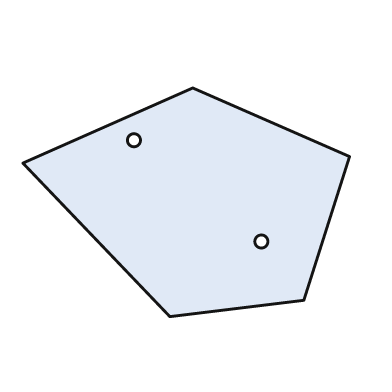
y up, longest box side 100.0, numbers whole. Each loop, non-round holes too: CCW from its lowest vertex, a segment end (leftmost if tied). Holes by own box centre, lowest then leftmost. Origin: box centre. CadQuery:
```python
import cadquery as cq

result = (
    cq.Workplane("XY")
    .moveTo(-5.0, -35.0)
    .lineTo(36.0, -30.0)
    .lineTo(50.0, 14.0)
    .lineTo(2.0, 35.0)
    .lineTo(-50.0, 12.0)
    .close()
    .moveTo(23.0, -12.0)
    .circle(2.0)
    .moveTo(-16.0, 19.0)
    .circle(2.0)
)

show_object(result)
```